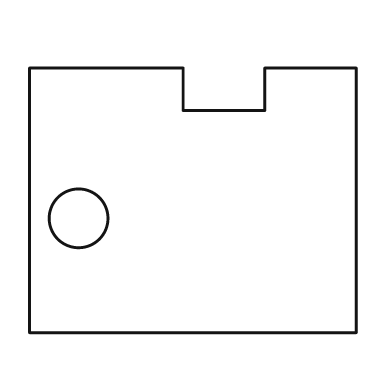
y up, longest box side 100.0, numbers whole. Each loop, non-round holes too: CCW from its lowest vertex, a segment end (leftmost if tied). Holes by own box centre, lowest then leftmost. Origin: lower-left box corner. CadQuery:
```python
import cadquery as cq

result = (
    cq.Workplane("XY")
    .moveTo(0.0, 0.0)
    .lineTo(100.0, 0.0)
    .lineTo(100.0, 81.0)
    .lineTo(72.0, 81.0)
    .lineTo(72.0, 68.0)
    .lineTo(47.0, 68.0)
    .lineTo(47.0, 81.0)
    .lineTo(0.0, 81.0)
    .close()
    .moveTo(15.0, 35.0)
    .circle(9.0)
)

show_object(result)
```